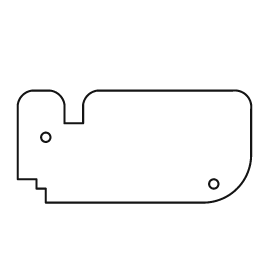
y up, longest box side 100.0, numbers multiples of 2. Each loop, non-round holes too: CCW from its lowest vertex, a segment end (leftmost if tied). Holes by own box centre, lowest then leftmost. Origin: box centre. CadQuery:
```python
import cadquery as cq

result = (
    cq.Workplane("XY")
    .moveTo(-38.0, -24.0)
    .lineTo(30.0, -24.0)
    .threePointArc((44.0, -18.0), (50.0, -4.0))
    .lineTo(50.0, 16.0)
    .threePointArc((48.0, 22.0), (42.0, 24.0))
    .lineTo(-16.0, 24.0)
    .threePointArc((-20.0, 22.0), (-22.0, 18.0))
    .lineTo(-22.0, 10.0)
    .lineTo(-30.0, 10.0)
    .lineTo(-30.0, 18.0)
    .threePointArc((-32.0, 22.0), (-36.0, 24.0))
    .lineTo(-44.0, 24.0)
    .threePointArc((-48.0, 22.0), (-50.0, 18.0))
    .lineTo(-50.0, -14.0)
    .lineTo(-42.0, -14.0)
    .lineTo(-42.0, -18.0)
    .lineTo(-38.0, -18.0)
    .close()
    .moveTo(34.0, -16.0)
    .circle(2.0)
    .moveTo(-38.0, 4.0)
    .circle(2.0)
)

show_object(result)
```